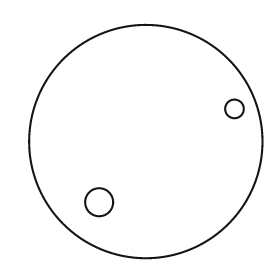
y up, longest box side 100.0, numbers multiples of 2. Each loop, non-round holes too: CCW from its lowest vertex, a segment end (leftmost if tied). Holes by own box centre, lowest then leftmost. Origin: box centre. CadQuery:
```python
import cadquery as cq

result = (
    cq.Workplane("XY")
    .moveTo(0.0, 0.0)
    .circle(50.0)
    .moveTo(-20.0, -26.0)
    .circle(6.0)
    .moveTo(38.0, 14.0)
    .circle(4.0)
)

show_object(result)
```